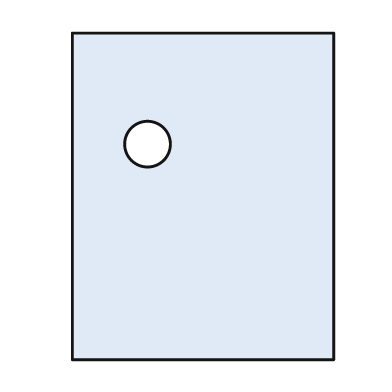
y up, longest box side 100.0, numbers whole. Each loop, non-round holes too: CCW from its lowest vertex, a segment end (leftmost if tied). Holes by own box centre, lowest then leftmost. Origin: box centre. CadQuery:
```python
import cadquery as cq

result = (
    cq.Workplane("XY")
    .moveTo(-40.0, -50.0)
    .lineTo(40.0, -50.0)
    .lineTo(40.0, 50.0)
    .lineTo(-40.0, 50.0)
    .close()
    .moveTo(-17.0, 16.0)
    .circle(7.0)
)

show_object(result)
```